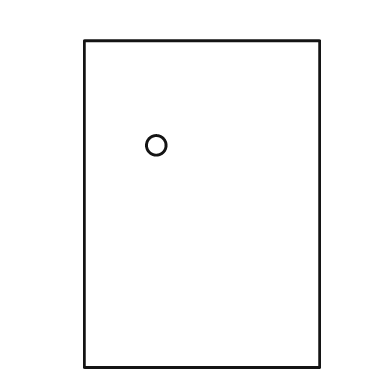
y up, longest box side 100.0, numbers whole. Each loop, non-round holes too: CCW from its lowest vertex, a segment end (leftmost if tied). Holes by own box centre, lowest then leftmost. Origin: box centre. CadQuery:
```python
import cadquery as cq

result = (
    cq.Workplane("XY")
    .moveTo(-36.0, -50.0)
    .lineTo(36.0, -50.0)
    .lineTo(36.0, 50.0)
    .lineTo(-36.0, 50.0)
    .close()
    .moveTo(-14.0, 18.0)
    .circle(3.0)
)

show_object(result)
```